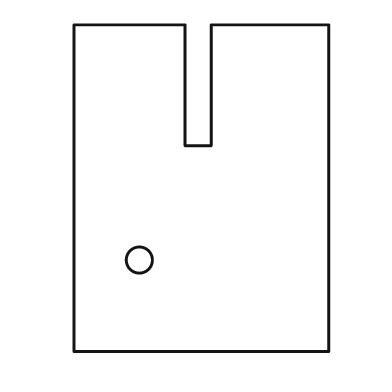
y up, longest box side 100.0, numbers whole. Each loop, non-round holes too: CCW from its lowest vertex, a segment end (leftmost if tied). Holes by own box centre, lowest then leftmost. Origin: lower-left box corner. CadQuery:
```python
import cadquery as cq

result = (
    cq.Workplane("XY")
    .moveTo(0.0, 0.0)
    .lineTo(78.0, 0.0)
    .lineTo(78.0, 100.0)
    .lineTo(42.0, 100.0)
    .lineTo(42.0, 63.0)
    .lineTo(34.0, 63.0)
    .lineTo(34.0, 100.0)
    .lineTo(0.0, 100.0)
    .close()
    .moveTo(20.0, 28.0)
    .circle(4.0)
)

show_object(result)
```